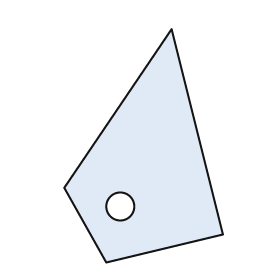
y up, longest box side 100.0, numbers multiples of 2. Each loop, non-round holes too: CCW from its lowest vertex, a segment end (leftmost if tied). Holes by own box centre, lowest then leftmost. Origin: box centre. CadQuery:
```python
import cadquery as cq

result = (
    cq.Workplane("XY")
    .moveTo(-16.0, -50.0)
    .lineTo(34.0, -38.0)
    .lineTo(12.0, 50.0)
    .lineTo(-34.0, -18.0)
    .close()
    .moveTo(-10.0, -26.0)
    .circle(6.0)
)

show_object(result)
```